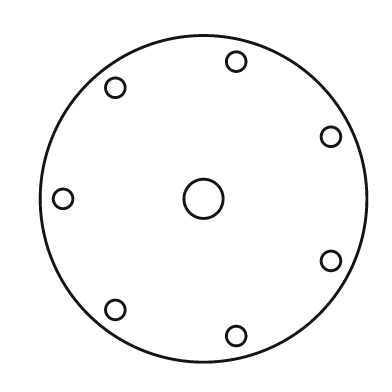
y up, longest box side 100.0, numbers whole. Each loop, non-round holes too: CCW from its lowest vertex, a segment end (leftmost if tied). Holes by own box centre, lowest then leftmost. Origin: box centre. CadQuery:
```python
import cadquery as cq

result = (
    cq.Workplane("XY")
    .moveTo(0.0, 0.0)
    .circle(50.0)
    .moveTo(10.0, -42.0)
    .circle(3.0)
    .moveTo(-27.0, -34.0)
    .circle(3.0)
    .moveTo(39.0, -19.0)
    .circle(3.0)
    .moveTo(-43.0, 0.0)
    .circle(3.0)
    .moveTo(0.0, 0.0)
    .circle(6.0)
    .moveTo(39.0, 19.0)
    .circle(3.0)
    .moveTo(-27.0, 34.0)
    .circle(3.0)
    .moveTo(10.0, 42.0)
    .circle(3.0)
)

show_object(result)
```